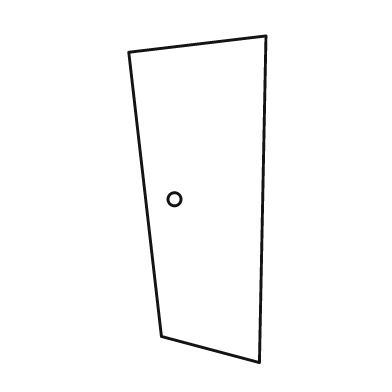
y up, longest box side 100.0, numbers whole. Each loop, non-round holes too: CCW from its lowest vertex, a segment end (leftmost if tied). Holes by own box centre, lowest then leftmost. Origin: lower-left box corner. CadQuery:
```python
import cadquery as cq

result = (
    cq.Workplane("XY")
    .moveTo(40.0, 0.0)
    .lineTo(42.0, 100.0)
    .lineTo(0.0, 95.0)
    .lineTo(10.0, 8.0)
    .close()
    .moveTo(14.0, 50.0)
    .circle(2.0)
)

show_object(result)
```